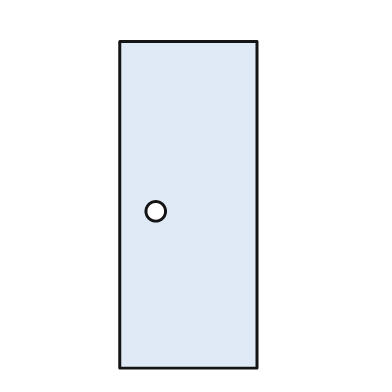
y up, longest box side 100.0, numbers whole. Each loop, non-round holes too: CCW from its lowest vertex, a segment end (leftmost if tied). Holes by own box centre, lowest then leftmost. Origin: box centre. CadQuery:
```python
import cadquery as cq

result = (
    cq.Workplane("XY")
    .moveTo(-21.0, -50.0)
    .lineTo(21.0, -50.0)
    .lineTo(21.0, 50.0)
    .lineTo(-21.0, 50.0)
    .close()
    .moveTo(-10.0, -2.0)
    .circle(3.0)
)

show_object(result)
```